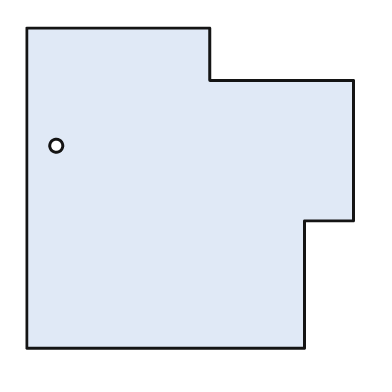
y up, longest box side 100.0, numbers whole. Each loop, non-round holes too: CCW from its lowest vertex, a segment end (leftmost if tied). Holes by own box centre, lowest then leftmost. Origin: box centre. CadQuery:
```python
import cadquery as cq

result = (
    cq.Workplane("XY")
    .moveTo(-50.0, -49.0)
    .lineTo(35.0, -49.0)
    .lineTo(35.0, -10.0)
    .lineTo(50.0, -10.0)
    .lineTo(50.0, 33.0)
    .lineTo(6.0, 33.0)
    .lineTo(6.0, 49.0)
    .lineTo(-50.0, 49.0)
    .close()
    .moveTo(-41.0, 13.0)
    .circle(2.0)
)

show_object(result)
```